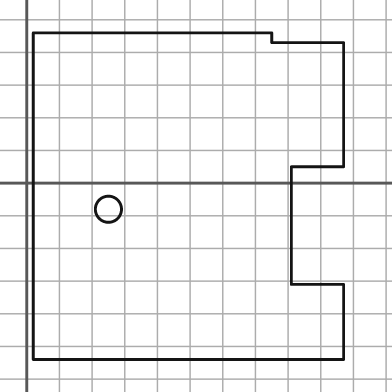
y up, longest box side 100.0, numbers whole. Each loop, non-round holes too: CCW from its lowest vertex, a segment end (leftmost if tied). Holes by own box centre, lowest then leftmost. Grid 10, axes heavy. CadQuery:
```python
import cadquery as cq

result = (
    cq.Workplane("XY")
    .moveTo(2.0, -54.0)
    .lineTo(97.0, -54.0)
    .lineTo(97.0, -31.0)
    .lineTo(81.0, -31.0)
    .lineTo(81.0, 5.0)
    .lineTo(97.0, 5.0)
    .lineTo(97.0, 43.0)
    .lineTo(75.0, 43.0)
    .lineTo(75.0, 46.0)
    .lineTo(2.0, 46.0)
    .close()
    .moveTo(25.0, -8.0)
    .circle(4.0)
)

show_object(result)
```